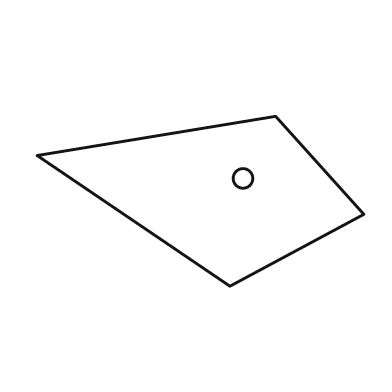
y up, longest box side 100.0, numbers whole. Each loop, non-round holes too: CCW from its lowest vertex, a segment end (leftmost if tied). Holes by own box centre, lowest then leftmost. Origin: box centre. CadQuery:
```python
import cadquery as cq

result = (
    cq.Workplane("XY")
    .moveTo(9.0, -26.0)
    .lineTo(50.0, -4.0)
    .lineTo(23.0, 26.0)
    .lineTo(-50.0, 14.0)
    .close()
    .moveTo(13.0, 7.0)
    .circle(3.0)
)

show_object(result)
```